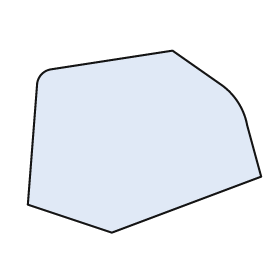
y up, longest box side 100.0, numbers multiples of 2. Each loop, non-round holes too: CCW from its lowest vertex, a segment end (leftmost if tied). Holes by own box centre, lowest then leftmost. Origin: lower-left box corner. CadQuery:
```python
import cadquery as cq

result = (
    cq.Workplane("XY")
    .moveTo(36.0, 0.0)
    .lineTo(100.0, 24.0)
    .lineTo(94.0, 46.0)
    .threePointArc((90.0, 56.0), (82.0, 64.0))
    .lineTo(62.0, 78.0)
    .lineTo(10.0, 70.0)
    .threePointArc((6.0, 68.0), (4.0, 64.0))
    .lineTo(0.0, 12.0)
    .close()
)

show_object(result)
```